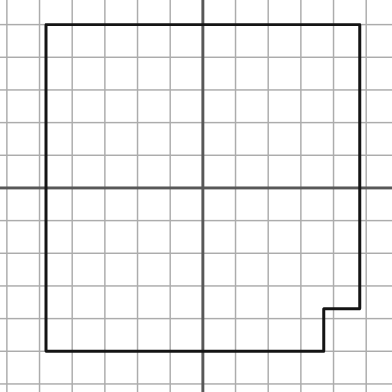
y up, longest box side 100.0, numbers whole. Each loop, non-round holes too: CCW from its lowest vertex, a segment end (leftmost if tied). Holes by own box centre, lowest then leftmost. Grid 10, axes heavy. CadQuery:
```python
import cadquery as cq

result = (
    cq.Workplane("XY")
    .moveTo(-48.0, -50.0)
    .lineTo(37.0, -50.0)
    .lineTo(37.0, -37.0)
    .lineTo(48.0, -37.0)
    .lineTo(48.0, 50.0)
    .lineTo(-48.0, 50.0)
    .close()
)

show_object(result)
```